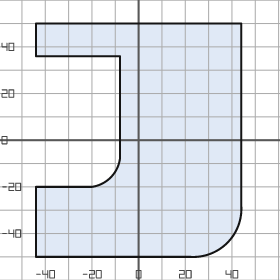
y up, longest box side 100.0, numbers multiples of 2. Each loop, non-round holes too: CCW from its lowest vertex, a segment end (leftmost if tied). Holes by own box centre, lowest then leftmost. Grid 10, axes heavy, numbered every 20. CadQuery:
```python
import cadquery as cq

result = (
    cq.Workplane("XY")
    .moveTo(-44.0, -50.0)
    .lineTo(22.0, -50.0)
    .threePointArc((38.0, -44.0), (44.0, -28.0))
    .lineTo(44.0, 50.0)
    .lineTo(-44.0, 50.0)
    .lineTo(-44.0, 36.0)
    .lineTo(-8.0, 36.0)
    .lineTo(-8.0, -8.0)
    .threePointArc((-12.0, -16.0), (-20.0, -20.0))
    .lineTo(-44.0, -20.0)
    .close()
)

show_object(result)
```